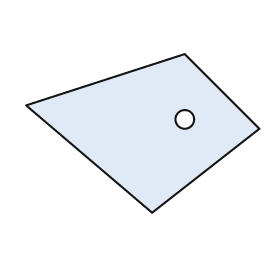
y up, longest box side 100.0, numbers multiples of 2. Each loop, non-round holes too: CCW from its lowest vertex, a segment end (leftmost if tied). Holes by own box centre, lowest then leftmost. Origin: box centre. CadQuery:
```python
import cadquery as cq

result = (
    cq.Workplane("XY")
    .moveTo(4.0, -34.0)
    .lineTo(50.0, 2.0)
    .lineTo(18.0, 34.0)
    .lineTo(-50.0, 12.0)
    .close()
    .moveTo(18.0, 6.0)
    .circle(4.0)
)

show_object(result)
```